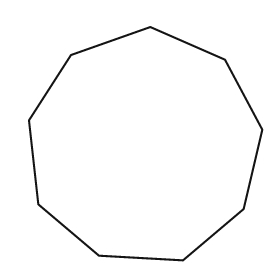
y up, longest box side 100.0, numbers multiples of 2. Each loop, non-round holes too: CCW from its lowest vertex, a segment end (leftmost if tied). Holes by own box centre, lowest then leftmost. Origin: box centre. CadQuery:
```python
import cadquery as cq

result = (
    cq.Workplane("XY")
    .moveTo(16.0, -50.0)
    .lineTo(42.0, -28.0)
    .lineTo(50.0, 6.0)
    .lineTo(34.0, 36.0)
    .lineTo(2.0, 50.0)
    .lineTo(-32.0, 38.0)
    .lineTo(-50.0, 10.0)
    .lineTo(-46.0, -26.0)
    .lineTo(-20.0, -48.0)
    .close()
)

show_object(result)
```